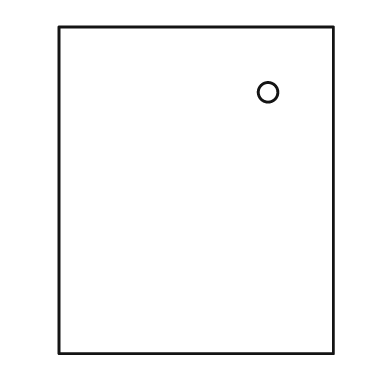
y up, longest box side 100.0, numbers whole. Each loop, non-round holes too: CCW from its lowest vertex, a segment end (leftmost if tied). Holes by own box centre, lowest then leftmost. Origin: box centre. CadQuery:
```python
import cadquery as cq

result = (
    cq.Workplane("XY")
    .moveTo(-42.0, -50.0)
    .lineTo(42.0, -50.0)
    .lineTo(42.0, 50.0)
    .lineTo(-42.0, 50.0)
    .close()
    .moveTo(22.0, 30.0)
    .circle(3.0)
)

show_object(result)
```